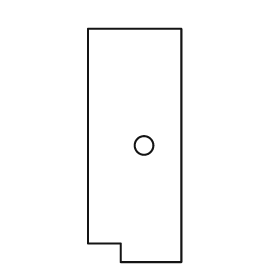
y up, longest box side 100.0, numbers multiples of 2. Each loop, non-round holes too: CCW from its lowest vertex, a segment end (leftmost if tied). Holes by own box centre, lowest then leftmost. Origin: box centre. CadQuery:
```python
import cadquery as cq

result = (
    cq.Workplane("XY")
    .moveTo(-6.0, -50.0)
    .lineTo(20.0, -50.0)
    .lineTo(20.0, 50.0)
    .lineTo(-20.0, 50.0)
    .lineTo(-20.0, -42.0)
    .lineTo(-6.0, -42.0)
    .close()
    .moveTo(4.0, 0.0)
    .circle(4.0)
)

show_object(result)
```